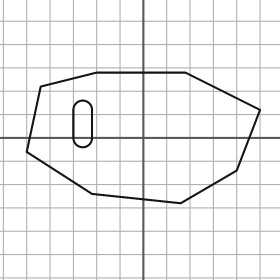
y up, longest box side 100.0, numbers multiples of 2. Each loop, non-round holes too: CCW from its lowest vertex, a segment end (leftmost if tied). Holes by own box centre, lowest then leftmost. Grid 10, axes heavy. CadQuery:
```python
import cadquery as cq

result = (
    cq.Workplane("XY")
    .moveTo(16.0, -28.0)
    .lineTo(40.0, -14.0)
    .lineTo(50.0, 12.0)
    .lineTo(18.0, 28.0)
    .lineTo(-20.0, 28.0)
    .lineTo(-44.0, 22.0)
    .lineTo(-50.0, -6.0)
    .lineTo(-22.0, -24.0)
    .close()
    .moveTo(-30.0, 0.0)
    .threePointArc((-26.0, -4.0), (-22.0, 0.0))
    .lineTo(-22.0, 12.0)
    .threePointArc((-26.0, 16.0), (-30.0, 12.0))
    .close()
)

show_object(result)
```